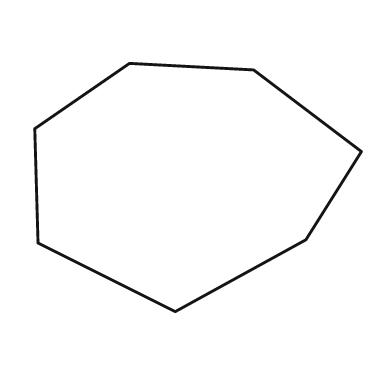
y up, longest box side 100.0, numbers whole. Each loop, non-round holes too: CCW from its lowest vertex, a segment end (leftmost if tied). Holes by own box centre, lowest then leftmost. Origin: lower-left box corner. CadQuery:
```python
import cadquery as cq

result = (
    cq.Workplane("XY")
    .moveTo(43.0, 0.0)
    .lineTo(83.0, 22.0)
    .lineTo(100.0, 49.0)
    .lineTo(67.0, 74.0)
    .lineTo(29.0, 76.0)
    .lineTo(0.0, 56.0)
    .lineTo(1.0, 21.0)
    .close()
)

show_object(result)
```